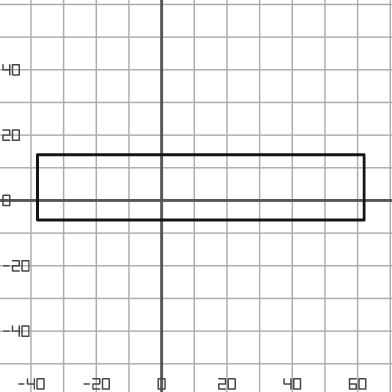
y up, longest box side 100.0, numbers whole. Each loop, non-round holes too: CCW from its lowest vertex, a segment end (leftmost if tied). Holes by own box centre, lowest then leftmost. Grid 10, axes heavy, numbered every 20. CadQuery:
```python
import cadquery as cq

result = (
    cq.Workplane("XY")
    .moveTo(-38.0, -6.0)
    .lineTo(62.0, -6.0)
    .lineTo(62.0, 14.0)
    .lineTo(-38.0, 14.0)
    .close()
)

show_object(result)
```